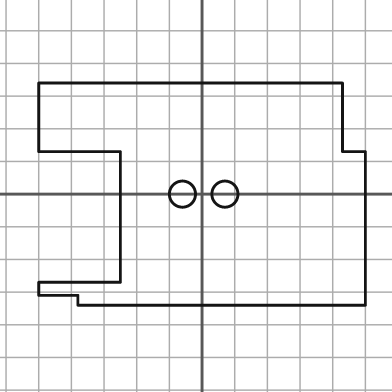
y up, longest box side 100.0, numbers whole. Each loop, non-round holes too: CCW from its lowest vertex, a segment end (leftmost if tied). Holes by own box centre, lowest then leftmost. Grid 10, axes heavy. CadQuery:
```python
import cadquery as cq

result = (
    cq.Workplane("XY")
    .moveTo(-38.0, -34.0)
    .lineTo(50.0, -34.0)
    .lineTo(50.0, 13.0)
    .lineTo(43.0, 13.0)
    .lineTo(43.0, 34.0)
    .lineTo(-50.0, 34.0)
    .lineTo(-50.0, 13.0)
    .lineTo(-25.0, 13.0)
    .lineTo(-25.0, -27.0)
    .lineTo(-50.0, -27.0)
    .lineTo(-50.0, -31.0)
    .lineTo(-38.0, -31.0)
    .close()
    .moveTo(-6.0, 0.0)
    .circle(4.0)
    .moveTo(7.0, 0.0)
    .circle(4.0)
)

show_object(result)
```